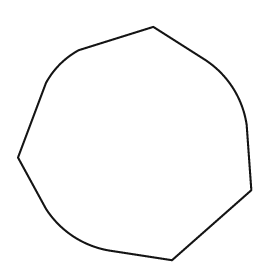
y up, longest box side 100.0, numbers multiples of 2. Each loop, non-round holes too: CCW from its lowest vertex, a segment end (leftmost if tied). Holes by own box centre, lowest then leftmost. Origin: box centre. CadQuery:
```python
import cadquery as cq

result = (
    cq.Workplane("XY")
    .moveTo(16.0, -50.0)
    .lineTo(50.0, -20.0)
    .lineTo(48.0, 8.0)
    .threePointArc((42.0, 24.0), (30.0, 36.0))
    .lineTo(8.0, 50.0)
    .lineTo(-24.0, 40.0)
    .threePointArc((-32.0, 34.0), (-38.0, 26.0))
    .lineTo(-50.0, -6.0)
    .lineTo(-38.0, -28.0)
    .threePointArc((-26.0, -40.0), (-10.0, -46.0))
    .close()
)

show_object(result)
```